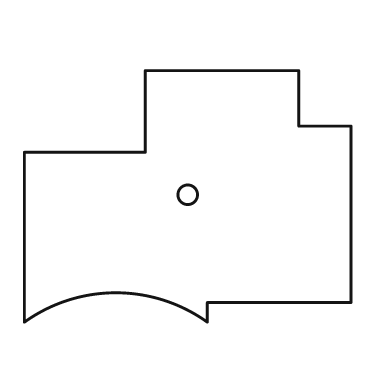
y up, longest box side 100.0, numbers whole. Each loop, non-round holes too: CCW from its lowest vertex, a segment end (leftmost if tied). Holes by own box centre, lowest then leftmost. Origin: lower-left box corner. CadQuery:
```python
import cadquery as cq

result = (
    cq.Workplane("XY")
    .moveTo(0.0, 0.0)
    .threePointArc((28.0, 9.0), (56.0, 0.0))
    .lineTo(56.0, 6.0)
    .lineTo(100.0, 6.0)
    .lineTo(100.0, 60.0)
    .lineTo(84.0, 60.0)
    .lineTo(84.0, 77.0)
    .lineTo(37.0, 77.0)
    .lineTo(37.0, 52.0)
    .lineTo(0.0, 52.0)
    .close()
    .moveTo(50.0, 39.0)
    .circle(3.0)
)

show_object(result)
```